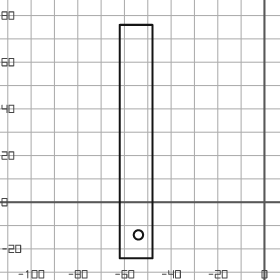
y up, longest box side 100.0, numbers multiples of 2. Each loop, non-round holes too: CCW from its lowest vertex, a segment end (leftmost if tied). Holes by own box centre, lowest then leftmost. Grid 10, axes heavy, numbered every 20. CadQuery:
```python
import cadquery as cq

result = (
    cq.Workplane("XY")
    .moveTo(-62.0, -24.0)
    .lineTo(-48.0, -24.0)
    .lineTo(-48.0, 76.0)
    .lineTo(-62.0, 76.0)
    .close()
    .moveTo(-54.0, -14.0)
    .circle(2.0)
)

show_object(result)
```